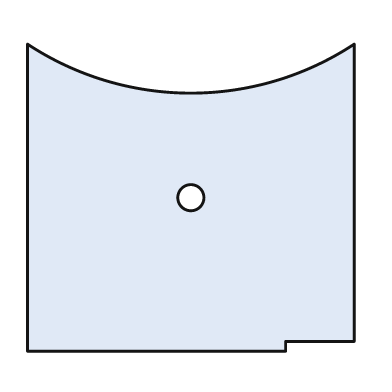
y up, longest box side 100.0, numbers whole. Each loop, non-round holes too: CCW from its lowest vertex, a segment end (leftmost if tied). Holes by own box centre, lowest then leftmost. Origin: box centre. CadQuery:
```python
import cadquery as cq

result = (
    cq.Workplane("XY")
    .moveTo(-50.0, -47.0)
    .lineTo(29.0, -47.0)
    .lineTo(29.0, -44.0)
    .lineTo(50.0, -44.0)
    .lineTo(50.0, 47.0)
    .threePointArc((0.0, 32.0), (-50.0, 47.0))
    .close()
    .moveTo(0.0, 0.0)
    .circle(4.0)
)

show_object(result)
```